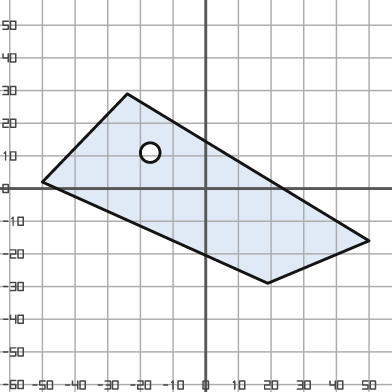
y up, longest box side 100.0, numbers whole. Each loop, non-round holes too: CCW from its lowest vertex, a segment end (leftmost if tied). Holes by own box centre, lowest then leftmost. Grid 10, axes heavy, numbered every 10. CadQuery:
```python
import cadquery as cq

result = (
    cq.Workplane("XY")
    .moveTo(19.0, -29.0)
    .lineTo(50.0, -16.0)
    .lineTo(-24.0, 29.0)
    .lineTo(-50.0, 2.0)
    .close()
    .moveTo(-17.0, 11.0)
    .circle(3.0)
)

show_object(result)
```